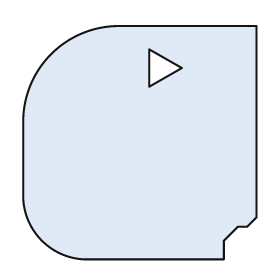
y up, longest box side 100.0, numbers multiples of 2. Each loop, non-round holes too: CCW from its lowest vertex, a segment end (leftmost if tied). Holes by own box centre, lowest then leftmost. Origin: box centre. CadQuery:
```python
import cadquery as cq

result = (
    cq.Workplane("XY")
    .moveTo(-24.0, -50.0)
    .lineTo(36.0, -50.0)
    .lineTo(36.0, -42.0)
    .lineTo(42.0, -36.0)
    .lineTo(46.0, -36.0)
    .lineTo(50.0, -32.0)
    .lineTo(50.0, 50.0)
    .lineTo(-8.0, 50.0)
    .threePointArc((-38.0, 38.0), (-50.0, 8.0))
    .lineTo(-50.0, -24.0)
    .threePointArc((-42.0, -42.0), (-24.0, -50.0))
    .close()
    .moveTo(4.0, 24.0)
    .lineTo(18.0, 32.0)
    .lineTo(4.0, 40.0)
    .close()
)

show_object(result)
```